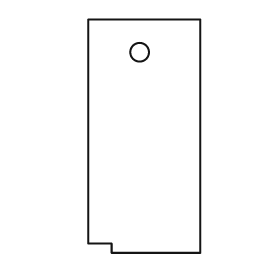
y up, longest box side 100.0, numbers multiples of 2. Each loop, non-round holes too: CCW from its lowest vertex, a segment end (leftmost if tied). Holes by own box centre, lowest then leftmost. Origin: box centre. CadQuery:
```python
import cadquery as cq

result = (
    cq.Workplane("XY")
    .moveTo(-14.0, -50.0)
    .lineTo(24.0, -50.0)
    .lineTo(24.0, 50.0)
    .lineTo(-24.0, 50.0)
    .lineTo(-24.0, -46.0)
    .lineTo(-14.0, -46.0)
    .close()
    .moveTo(-2.0, 36.0)
    .circle(4.0)
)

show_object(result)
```